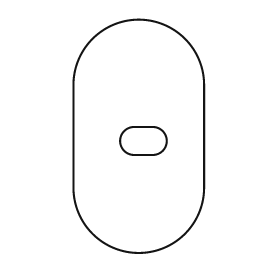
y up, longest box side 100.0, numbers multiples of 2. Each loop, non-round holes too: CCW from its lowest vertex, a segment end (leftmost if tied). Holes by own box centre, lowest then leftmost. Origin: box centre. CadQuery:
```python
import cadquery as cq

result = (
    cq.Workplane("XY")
    .moveTo(-28.0, -22.0)
    .threePointArc((0.0, -50.0), (28.0, -22.0))
    .lineTo(28.0, 22.0)
    .threePointArc((0.0, 50.0), (-28.0, 22.0))
    .close()
    .moveTo(-2.0, -8.0)
    .lineTo(6.0, -8.0)
    .threePointArc((12.0, -2.0), (6.0, 4.0))
    .lineTo(-2.0, 4.0)
    .threePointArc((-8.0, -2.0), (-2.0, -8.0))
    .close()
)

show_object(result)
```